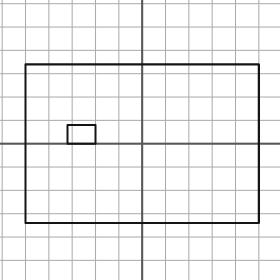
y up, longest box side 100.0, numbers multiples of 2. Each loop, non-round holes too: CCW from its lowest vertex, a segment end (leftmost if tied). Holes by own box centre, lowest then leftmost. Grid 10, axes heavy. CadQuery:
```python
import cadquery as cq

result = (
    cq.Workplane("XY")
    .moveTo(-50.0, -34.0)
    .lineTo(50.0, -34.0)
    .lineTo(50.0, 34.0)
    .lineTo(-50.0, 34.0)
    .close()
    .moveTo(-32.0, 0.0)
    .lineTo(-20.0, 0.0)
    .lineTo(-20.0, 8.0)
    .lineTo(-32.0, 8.0)
    .close()
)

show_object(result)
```